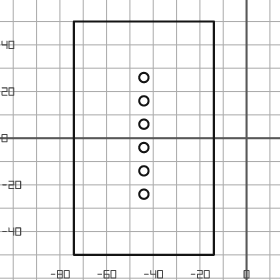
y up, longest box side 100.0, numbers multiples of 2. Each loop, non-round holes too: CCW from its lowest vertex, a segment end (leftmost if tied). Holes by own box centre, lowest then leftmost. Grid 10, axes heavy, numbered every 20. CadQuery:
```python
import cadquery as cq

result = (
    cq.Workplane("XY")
    .moveTo(-74.0, -50.0)
    .lineTo(-14.0, -50.0)
    .lineTo(-14.0, 50.0)
    .lineTo(-74.0, 50.0)
    .close()
    .moveTo(-44.0, -24.0)
    .circle(2.0)
    .moveTo(-44.0, -14.0)
    .circle(2.0)
    .moveTo(-44.0, -4.0)
    .circle(2.0)
    .moveTo(-44.0, 6.0)
    .circle(2.0)
    .moveTo(-44.0, 16.0)
    .circle(2.0)
    .moveTo(-44.0, 26.0)
    .circle(2.0)
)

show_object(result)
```